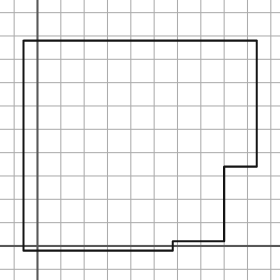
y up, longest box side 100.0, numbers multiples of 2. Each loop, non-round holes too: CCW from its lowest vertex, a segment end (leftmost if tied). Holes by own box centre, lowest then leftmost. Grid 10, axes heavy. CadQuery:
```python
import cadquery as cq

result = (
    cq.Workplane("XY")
    .moveTo(-6.0, -2.0)
    .lineTo(58.0, -2.0)
    .lineTo(58.0, 2.0)
    .lineTo(80.0, 2.0)
    .lineTo(80.0, 34.0)
    .lineTo(94.0, 34.0)
    .lineTo(94.0, 88.0)
    .lineTo(-6.0, 88.0)
    .close()
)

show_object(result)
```